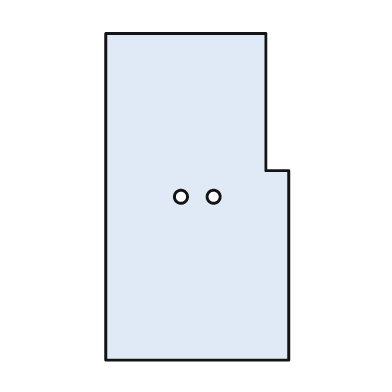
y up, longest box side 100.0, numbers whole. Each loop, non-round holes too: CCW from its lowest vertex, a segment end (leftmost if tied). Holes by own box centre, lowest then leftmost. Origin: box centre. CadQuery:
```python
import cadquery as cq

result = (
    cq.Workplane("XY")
    .moveTo(-28.0, -50.0)
    .lineTo(28.0, -50.0)
    .lineTo(28.0, 8.0)
    .lineTo(21.0, 8.0)
    .lineTo(21.0, 50.0)
    .lineTo(-28.0, 50.0)
    .close()
    .moveTo(-5.0, 0.0)
    .circle(2.0)
    .moveTo(5.0, 0.0)
    .circle(2.0)
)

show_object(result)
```